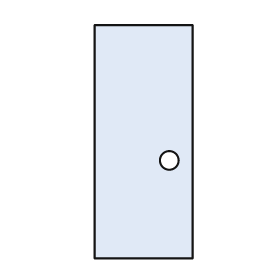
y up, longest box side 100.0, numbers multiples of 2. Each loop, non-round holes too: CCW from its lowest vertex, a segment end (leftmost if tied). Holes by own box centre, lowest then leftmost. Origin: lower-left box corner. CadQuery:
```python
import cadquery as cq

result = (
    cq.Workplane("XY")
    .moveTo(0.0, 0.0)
    .lineTo(42.0, 0.0)
    .lineTo(42.0, 100.0)
    .lineTo(0.0, 100.0)
    .close()
    .moveTo(32.0, 42.0)
    .circle(4.0)
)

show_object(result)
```